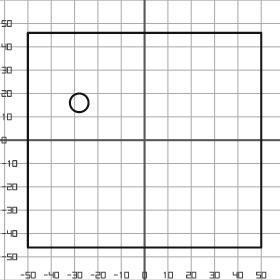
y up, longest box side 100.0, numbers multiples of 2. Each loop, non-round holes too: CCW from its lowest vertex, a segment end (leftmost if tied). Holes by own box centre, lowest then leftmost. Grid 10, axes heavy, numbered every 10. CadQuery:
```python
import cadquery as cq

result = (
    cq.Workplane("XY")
    .moveTo(-50.0, -46.0)
    .lineTo(50.0, -46.0)
    .lineTo(50.0, 46.0)
    .lineTo(-50.0, 46.0)
    .close()
    .moveTo(-28.0, 16.0)
    .circle(4.0)
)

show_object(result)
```